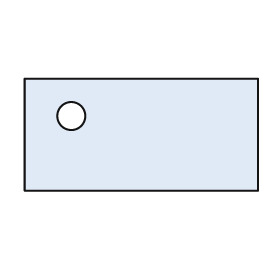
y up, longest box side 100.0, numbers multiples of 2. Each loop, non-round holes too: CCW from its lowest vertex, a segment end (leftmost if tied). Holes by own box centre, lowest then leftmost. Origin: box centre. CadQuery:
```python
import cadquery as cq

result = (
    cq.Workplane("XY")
    .moveTo(-50.0, -24.0)
    .lineTo(50.0, -24.0)
    .lineTo(50.0, 24.0)
    .lineTo(-50.0, 24.0)
    .close()
    .moveTo(-30.0, 8.0)
    .circle(6.0)
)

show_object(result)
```